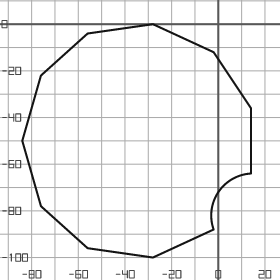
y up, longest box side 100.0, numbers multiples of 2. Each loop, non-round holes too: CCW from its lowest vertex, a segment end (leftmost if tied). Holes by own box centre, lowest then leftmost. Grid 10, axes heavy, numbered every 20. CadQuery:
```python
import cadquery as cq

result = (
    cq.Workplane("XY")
    .moveTo(-28.0, -100.0)
    .lineTo(-2.0, -88.0)
    .threePointArc((0.0, -72.0), (14.0, -64.0))
    .lineTo(14.0, -36.0)
    .lineTo(-2.0, -12.0)
    .lineTo(-28.0, 0.0)
    .lineTo(-56.0, -4.0)
    .lineTo(-76.0, -22.0)
    .lineTo(-84.0, -50.0)
    .lineTo(-76.0, -78.0)
    .lineTo(-56.0, -96.0)
    .close()
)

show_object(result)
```